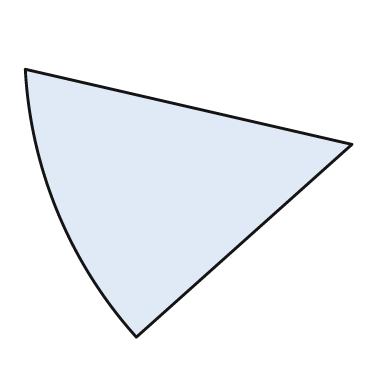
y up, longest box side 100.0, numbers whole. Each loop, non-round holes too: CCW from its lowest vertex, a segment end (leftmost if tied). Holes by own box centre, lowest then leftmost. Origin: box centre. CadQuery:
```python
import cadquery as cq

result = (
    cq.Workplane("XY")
    .moveTo(-16.0, -41.0)
    .lineTo(50.0, 18.0)
    .lineTo(-50.0, 41.0)
    .threePointArc((-40.0, -3.0), (-16.0, -41.0))
    .close()
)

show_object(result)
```